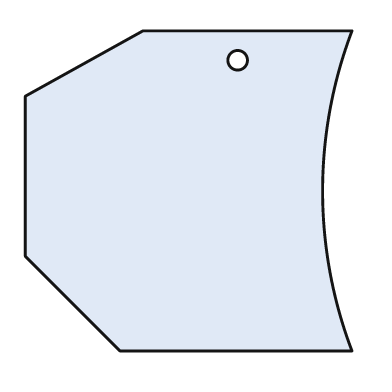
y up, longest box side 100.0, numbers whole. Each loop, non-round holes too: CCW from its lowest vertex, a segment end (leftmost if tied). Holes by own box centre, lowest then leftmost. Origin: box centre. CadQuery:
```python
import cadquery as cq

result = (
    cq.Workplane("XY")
    .moveTo(-21.0, -49.0)
    .lineTo(50.0, -49.0)
    .threePointArc((41.0, 0.0), (50.0, 49.0))
    .lineTo(-14.0, 49.0)
    .lineTo(-50.0, 29.0)
    .lineTo(-50.0, -20.0)
    .close()
    .moveTo(15.0, 40.0)
    .circle(3.0)
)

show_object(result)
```